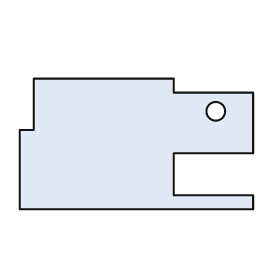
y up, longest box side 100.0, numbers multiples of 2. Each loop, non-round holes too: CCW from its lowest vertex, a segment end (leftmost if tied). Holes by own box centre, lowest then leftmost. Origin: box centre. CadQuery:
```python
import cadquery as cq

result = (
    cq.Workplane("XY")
    .moveTo(-50.0, -28.0)
    .lineTo(50.0, -28.0)
    .lineTo(50.0, -22.0)
    .lineTo(16.0, -22.0)
    .lineTo(16.0, -4.0)
    .lineTo(50.0, -4.0)
    .lineTo(50.0, 22.0)
    .lineTo(16.0, 22.0)
    .lineTo(16.0, 28.0)
    .lineTo(-44.0, 28.0)
    .lineTo(-44.0, 6.0)
    .lineTo(-50.0, 6.0)
    .close()
    .moveTo(34.0, 14.0)
    .circle(4.0)
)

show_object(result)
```